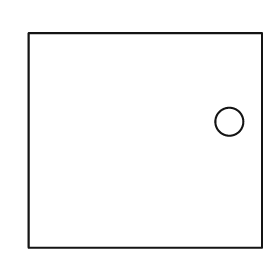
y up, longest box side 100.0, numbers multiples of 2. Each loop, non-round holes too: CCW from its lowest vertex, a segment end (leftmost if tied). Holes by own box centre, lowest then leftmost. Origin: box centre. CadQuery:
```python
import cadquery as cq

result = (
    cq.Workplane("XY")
    .moveTo(-50.0, -46.0)
    .lineTo(50.0, -46.0)
    .lineTo(50.0, 46.0)
    .lineTo(-50.0, 46.0)
    .close()
    .moveTo(36.0, 8.0)
    .circle(6.0)
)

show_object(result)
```